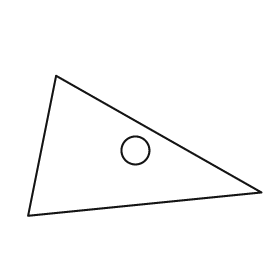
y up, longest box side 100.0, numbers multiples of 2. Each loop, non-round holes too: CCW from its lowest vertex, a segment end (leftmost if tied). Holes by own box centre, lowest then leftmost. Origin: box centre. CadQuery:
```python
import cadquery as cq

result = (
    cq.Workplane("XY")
    .moveTo(-50.0, -30.0)
    .lineTo(50.0, -20.0)
    .lineTo(-38.0, 30.0)
    .close()
    .moveTo(-4.0, -2.0)
    .circle(6.0)
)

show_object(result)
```